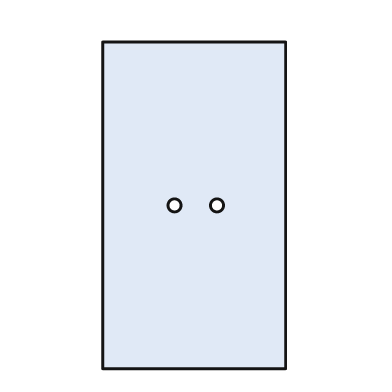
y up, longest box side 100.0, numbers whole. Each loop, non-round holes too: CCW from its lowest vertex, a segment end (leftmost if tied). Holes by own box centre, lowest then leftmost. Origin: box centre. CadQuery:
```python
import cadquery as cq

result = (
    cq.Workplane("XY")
    .moveTo(-28.0, -50.0)
    .lineTo(28.0, -50.0)
    .lineTo(28.0, 50.0)
    .lineTo(-28.0, 50.0)
    .close()
    .moveTo(-6.0, 0.0)
    .circle(2.0)
    .moveTo(7.0, 0.0)
    .circle(2.0)
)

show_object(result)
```